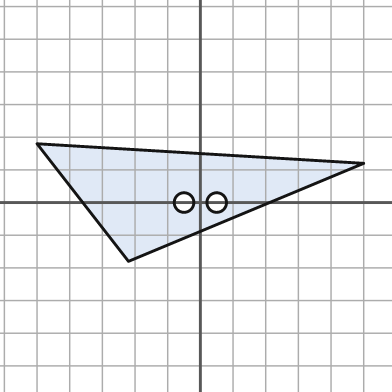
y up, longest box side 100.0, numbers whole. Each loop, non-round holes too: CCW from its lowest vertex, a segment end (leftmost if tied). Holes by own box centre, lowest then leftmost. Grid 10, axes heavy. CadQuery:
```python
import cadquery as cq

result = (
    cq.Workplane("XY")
    .moveTo(-22.0, -18.0)
    .lineTo(50.0, 12.0)
    .lineTo(-50.0, 18.0)
    .close()
    .moveTo(-5.0, 0.0)
    .circle(3.0)
    .moveTo(5.0, 0.0)
    .circle(3.0)
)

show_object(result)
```